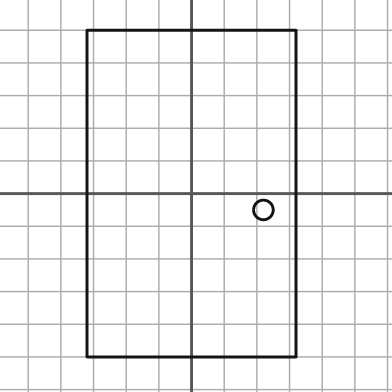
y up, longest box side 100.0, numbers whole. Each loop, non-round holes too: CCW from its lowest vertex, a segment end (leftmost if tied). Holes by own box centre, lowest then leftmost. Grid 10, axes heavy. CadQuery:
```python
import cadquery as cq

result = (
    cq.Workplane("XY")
    .moveTo(-32.0, -50.0)
    .lineTo(32.0, -50.0)
    .lineTo(32.0, 50.0)
    .lineTo(-32.0, 50.0)
    .close()
    .moveTo(22.0, -5.0)
    .circle(3.0)
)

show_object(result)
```